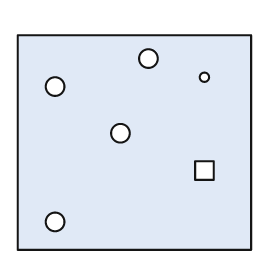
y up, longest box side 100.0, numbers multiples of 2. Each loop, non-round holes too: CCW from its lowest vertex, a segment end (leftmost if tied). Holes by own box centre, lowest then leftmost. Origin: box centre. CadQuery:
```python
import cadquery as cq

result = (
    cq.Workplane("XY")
    .moveTo(-50.0, -46.0)
    .lineTo(50.0, -46.0)
    .lineTo(50.0, 46.0)
    .lineTo(-50.0, 46.0)
    .close()
    .moveTo(-34.0, -34.0)
    .circle(4.0)
    .moveTo(26.0, -16.0)
    .lineTo(34.0, -16.0)
    .lineTo(34.0, -8.0)
    .lineTo(26.0, -8.0)
    .close()
    .moveTo(-6.0, 4.0)
    .circle(4.0)
    .moveTo(-34.0, 24.0)
    .circle(4.0)
    .moveTo(30.0, 28.0)
    .circle(2.0)
    .moveTo(6.0, 36.0)
    .circle(4.0)
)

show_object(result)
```